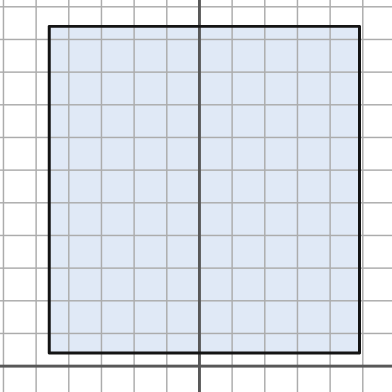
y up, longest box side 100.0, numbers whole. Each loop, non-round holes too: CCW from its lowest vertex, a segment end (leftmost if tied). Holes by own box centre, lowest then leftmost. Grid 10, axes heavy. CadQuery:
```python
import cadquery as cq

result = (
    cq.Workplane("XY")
    .moveTo(-46.0, 4.0)
    .lineTo(49.0, 4.0)
    .lineTo(49.0, 104.0)
    .lineTo(-46.0, 104.0)
    .close()
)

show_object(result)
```